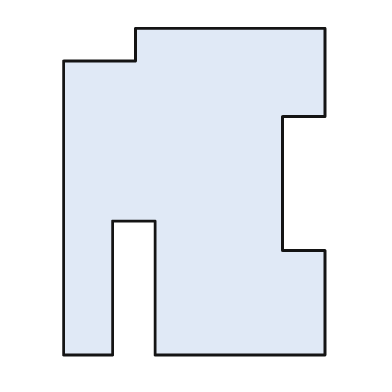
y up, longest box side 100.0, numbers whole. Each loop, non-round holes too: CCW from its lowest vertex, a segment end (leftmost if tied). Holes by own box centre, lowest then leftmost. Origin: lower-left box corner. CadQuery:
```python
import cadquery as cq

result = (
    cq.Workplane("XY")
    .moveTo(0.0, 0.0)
    .lineTo(15.0, 0.0)
    .lineTo(15.0, 41.0)
    .lineTo(28.0, 41.0)
    .lineTo(28.0, 0.0)
    .lineTo(80.0, 0.0)
    .lineTo(80.0, 32.0)
    .lineTo(67.0, 32.0)
    .lineTo(67.0, 73.0)
    .lineTo(80.0, 73.0)
    .lineTo(80.0, 100.0)
    .lineTo(22.0, 100.0)
    .lineTo(22.0, 90.0)
    .lineTo(0.0, 90.0)
    .close()
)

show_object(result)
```